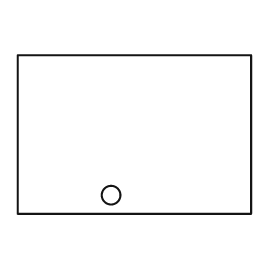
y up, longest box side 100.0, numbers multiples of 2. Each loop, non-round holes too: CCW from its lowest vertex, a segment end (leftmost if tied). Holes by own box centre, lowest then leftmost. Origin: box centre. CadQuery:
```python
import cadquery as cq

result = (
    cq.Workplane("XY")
    .moveTo(-50.0, -34.0)
    .lineTo(50.0, -34.0)
    .lineTo(50.0, 34.0)
    .lineTo(-50.0, 34.0)
    .close()
    .moveTo(-10.0, -26.0)
    .circle(4.0)
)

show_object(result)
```